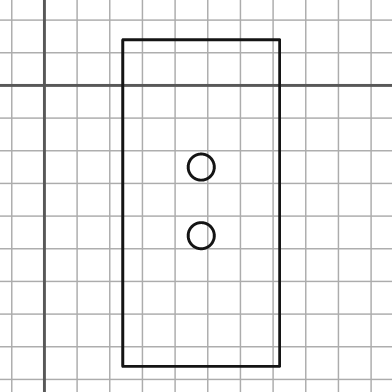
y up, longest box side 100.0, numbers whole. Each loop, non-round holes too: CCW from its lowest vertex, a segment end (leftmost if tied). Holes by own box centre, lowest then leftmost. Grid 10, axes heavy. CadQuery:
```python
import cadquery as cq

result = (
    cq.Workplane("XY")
    .moveTo(24.0, -86.0)
    .lineTo(72.0, -86.0)
    .lineTo(72.0, 14.0)
    .lineTo(24.0, 14.0)
    .close()
    .moveTo(48.0, -46.0)
    .circle(4.0)
    .moveTo(48.0, -25.0)
    .circle(4.0)
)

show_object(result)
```